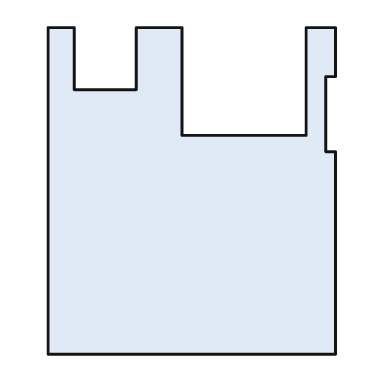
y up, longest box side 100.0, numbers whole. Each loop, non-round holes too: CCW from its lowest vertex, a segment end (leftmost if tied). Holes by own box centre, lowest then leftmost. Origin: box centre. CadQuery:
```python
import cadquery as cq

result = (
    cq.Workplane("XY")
    .moveTo(-44.0, -50.0)
    .lineTo(44.0, -50.0)
    .lineTo(44.0, 12.0)
    .lineTo(41.0, 12.0)
    .lineTo(41.0, 35.0)
    .lineTo(44.0, 35.0)
    .lineTo(44.0, 50.0)
    .lineTo(35.0, 50.0)
    .lineTo(35.0, 17.0)
    .lineTo(-3.0, 17.0)
    .lineTo(-3.0, 50.0)
    .lineTo(-17.0, 50.0)
    .lineTo(-17.0, 31.0)
    .lineTo(-36.0, 31.0)
    .lineTo(-36.0, 50.0)
    .lineTo(-44.0, 50.0)
    .close()
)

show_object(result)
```